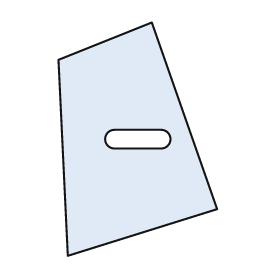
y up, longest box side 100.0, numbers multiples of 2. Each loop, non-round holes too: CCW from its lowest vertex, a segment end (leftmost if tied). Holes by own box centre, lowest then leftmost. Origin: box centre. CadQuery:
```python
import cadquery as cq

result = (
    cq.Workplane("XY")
    .moveTo(-30.0, -50.0)
    .lineTo(34.0, -30.0)
    .lineTo(6.0, 50.0)
    .lineTo(-34.0, 34.0)
    .close()
    .moveTo(-10.0, -4.0)
    .lineTo(10.0, -4.0)
    .threePointArc((14.0, 0.0), (10.0, 4.0))
    .lineTo(-10.0, 4.0)
    .threePointArc((-14.0, 0.0), (-10.0, -4.0))
    .close()
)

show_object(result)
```